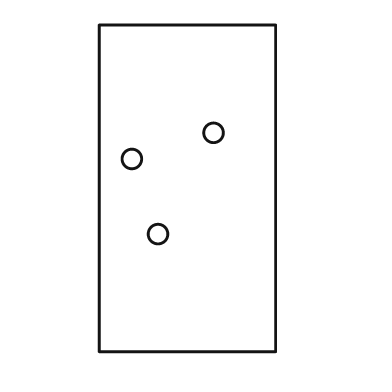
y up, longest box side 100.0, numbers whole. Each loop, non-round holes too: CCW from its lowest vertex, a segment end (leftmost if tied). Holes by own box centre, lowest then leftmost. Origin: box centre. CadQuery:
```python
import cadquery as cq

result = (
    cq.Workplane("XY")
    .moveTo(-27.0, -50.0)
    .lineTo(27.0, -50.0)
    .lineTo(27.0, 50.0)
    .lineTo(-27.0, 50.0)
    .close()
    .moveTo(-9.0, -14.0)
    .circle(3.0)
    .moveTo(-17.0, 9.0)
    .circle(3.0)
    .moveTo(8.0, 17.0)
    .circle(3.0)
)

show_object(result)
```